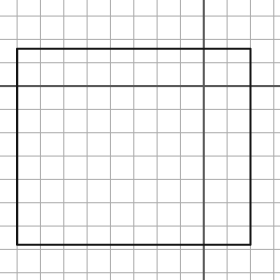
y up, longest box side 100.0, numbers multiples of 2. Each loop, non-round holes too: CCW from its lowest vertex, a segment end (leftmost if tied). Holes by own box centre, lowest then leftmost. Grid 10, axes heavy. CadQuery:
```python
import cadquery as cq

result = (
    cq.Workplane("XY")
    .moveTo(-80.0, -68.0)
    .lineTo(20.0, -68.0)
    .lineTo(20.0, 16.0)
    .lineTo(-80.0, 16.0)
    .close()
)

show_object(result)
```